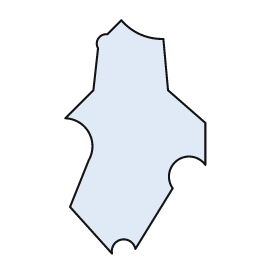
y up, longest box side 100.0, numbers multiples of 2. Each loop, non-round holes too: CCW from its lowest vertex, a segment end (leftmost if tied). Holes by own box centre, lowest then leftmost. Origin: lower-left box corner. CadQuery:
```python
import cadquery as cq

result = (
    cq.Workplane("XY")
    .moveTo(20.0, 0.0)
    .threePointArc((24.0, 6.0), (30.0, 2.0))
    .lineTo(46.0, 28.0)
    .threePointArc((48.0, 40.0), (60.0, 38.0))
    .lineTo(60.0, 56.0)
    .lineTo(44.0, 70.0)
    .lineTo(42.0, 92.0)
    .threePointArc((32.0, 94.0), (24.0, 100.0))
    .lineTo(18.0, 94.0)
    .threePointArc((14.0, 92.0), (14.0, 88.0))
    .lineTo(12.0, 70.0)
    .lineTo(0.0, 58.0)
    .threePointArc((10.0, 52.0), (10.0, 40.0))
    .lineTo(2.0, 20.0)
    .close()
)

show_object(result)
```